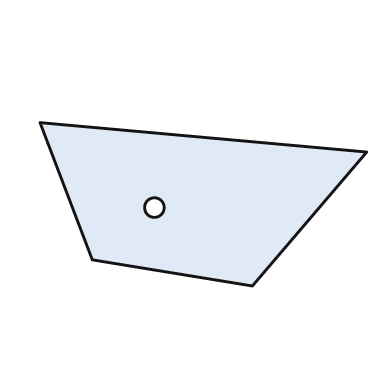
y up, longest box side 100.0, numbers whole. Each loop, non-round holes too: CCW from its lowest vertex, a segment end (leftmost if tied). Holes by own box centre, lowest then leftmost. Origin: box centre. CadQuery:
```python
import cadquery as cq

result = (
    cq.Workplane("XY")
    .moveTo(15.0, -25.0)
    .lineTo(50.0, 16.0)
    .lineTo(-50.0, 25.0)
    .lineTo(-34.0, -17.0)
    .close()
    .moveTo(-15.0, -1.0)
    .circle(3.0)
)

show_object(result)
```